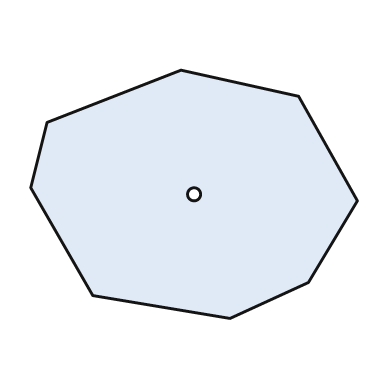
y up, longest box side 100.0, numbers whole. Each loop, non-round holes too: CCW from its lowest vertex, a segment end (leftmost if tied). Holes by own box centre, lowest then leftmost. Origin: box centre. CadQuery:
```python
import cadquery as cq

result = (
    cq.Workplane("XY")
    .moveTo(11.0, -38.0)
    .lineTo(35.0, -27.0)
    .lineTo(50.0, -2.0)
    .lineTo(32.0, 30.0)
    .lineTo(-4.0, 38.0)
    .lineTo(-45.0, 22.0)
    .lineTo(-50.0, 2.0)
    .lineTo(-31.0, -31.0)
    .close()
    .moveTo(0.0, 0.0)
    .circle(2.0)
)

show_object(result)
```